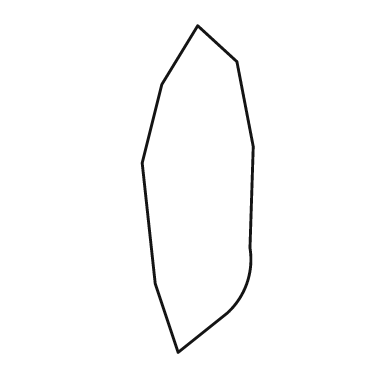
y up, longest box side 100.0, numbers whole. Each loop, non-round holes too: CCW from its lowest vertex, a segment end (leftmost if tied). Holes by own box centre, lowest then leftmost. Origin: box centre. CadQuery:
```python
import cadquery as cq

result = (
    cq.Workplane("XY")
    .moveTo(-6.0, -50.0)
    .lineTo(9.0, -38.0)
    .threePointArc((15.0, -29.0), (16.0, -18.0))
    .lineTo(17.0, 13.0)
    .lineTo(12.0, 39.0)
    .lineTo(0.0, 50.0)
    .lineTo(-11.0, 32.0)
    .lineTo(-17.0, 8.0)
    .lineTo(-13.0, -29.0)
    .close()
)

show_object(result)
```